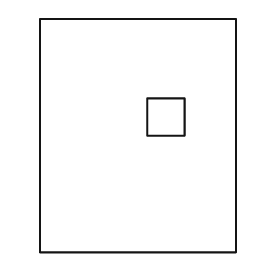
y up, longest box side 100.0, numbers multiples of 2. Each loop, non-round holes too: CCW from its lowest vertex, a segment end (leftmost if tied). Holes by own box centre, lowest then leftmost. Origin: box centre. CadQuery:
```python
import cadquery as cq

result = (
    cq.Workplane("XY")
    .moveTo(-42.0, -50.0)
    .lineTo(42.0, -50.0)
    .lineTo(42.0, 50.0)
    .lineTo(-42.0, 50.0)
    .close()
    .moveTo(4.0, 0.0)
    .lineTo(20.0, 0.0)
    .lineTo(20.0, 16.0)
    .lineTo(4.0, 16.0)
    .close()
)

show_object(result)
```